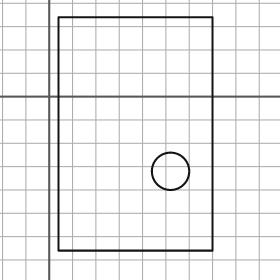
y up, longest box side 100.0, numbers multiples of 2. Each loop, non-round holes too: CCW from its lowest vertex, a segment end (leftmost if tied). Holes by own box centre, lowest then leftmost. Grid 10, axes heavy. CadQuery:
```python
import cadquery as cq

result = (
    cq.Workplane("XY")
    .moveTo(4.0, -66.0)
    .lineTo(70.0, -66.0)
    .lineTo(70.0, 34.0)
    .lineTo(4.0, 34.0)
    .close()
    .moveTo(52.0, -32.0)
    .circle(8.0)
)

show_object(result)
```